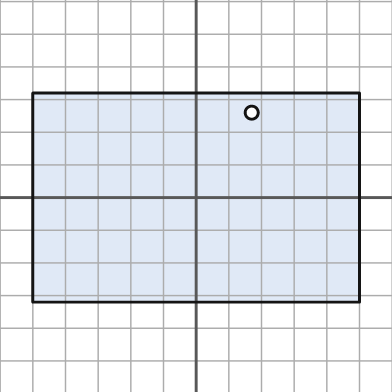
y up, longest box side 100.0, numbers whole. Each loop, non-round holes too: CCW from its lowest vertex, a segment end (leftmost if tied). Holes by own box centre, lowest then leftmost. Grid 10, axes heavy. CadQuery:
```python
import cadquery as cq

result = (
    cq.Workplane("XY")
    .moveTo(-50.0, -32.0)
    .lineTo(50.0, -32.0)
    .lineTo(50.0, 32.0)
    .lineTo(-50.0, 32.0)
    .close()
    .moveTo(17.0, 26.0)
    .circle(2.0)
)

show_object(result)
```